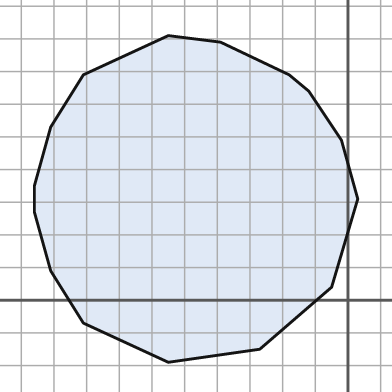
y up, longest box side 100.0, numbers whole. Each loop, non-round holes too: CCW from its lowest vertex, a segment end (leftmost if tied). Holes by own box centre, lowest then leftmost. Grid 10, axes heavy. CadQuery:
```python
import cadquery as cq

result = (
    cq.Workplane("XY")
    .moveTo(-55.0, -19.0)
    .lineTo(-27.0, -15.0)
    .lineTo(-5.0, 4.0)
    .lineTo(3.0, 31.0)
    .lineTo(-2.0, 49.0)
    .lineTo(-12.0, 64.0)
    .lineTo(-18.0, 69.0)
    .lineTo(-39.0, 79.0)
    .lineTo(-55.0, 81.0)
    .lineTo(-81.0, 69.0)
    .lineTo(-91.0, 53.0)
    .lineTo(-96.0, 35.0)
    .lineTo(-96.0, 27.0)
    .lineTo(-91.0, 9.0)
    .lineTo(-81.0, -7.0)
    .close()
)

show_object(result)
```